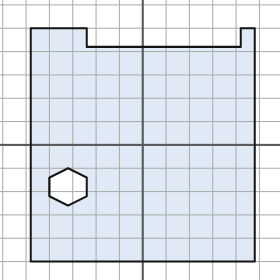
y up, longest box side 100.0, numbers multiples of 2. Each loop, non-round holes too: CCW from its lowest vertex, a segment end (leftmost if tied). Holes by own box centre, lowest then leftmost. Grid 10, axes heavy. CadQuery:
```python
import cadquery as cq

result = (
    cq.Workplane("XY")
    .moveTo(-48.0, -50.0)
    .lineTo(48.0, -50.0)
    .lineTo(48.0, 50.0)
    .lineTo(42.0, 50.0)
    .lineTo(42.0, 42.0)
    .lineTo(-24.0, 42.0)
    .lineTo(-24.0, 50.0)
    .lineTo(-48.0, 50.0)
    .close()
    .moveTo(-32.0, -26.0)
    .lineTo(-24.0, -22.0)
    .lineTo(-24.0, -14.0)
    .lineTo(-32.0, -10.0)
    .lineTo(-40.0, -14.0)
    .lineTo(-40.0, -22.0)
    .close()
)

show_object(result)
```